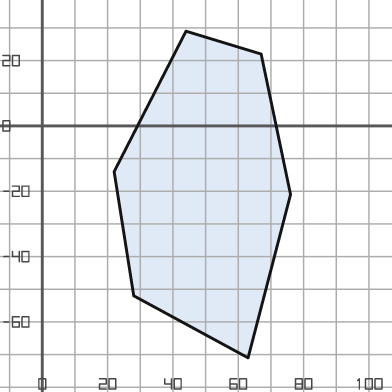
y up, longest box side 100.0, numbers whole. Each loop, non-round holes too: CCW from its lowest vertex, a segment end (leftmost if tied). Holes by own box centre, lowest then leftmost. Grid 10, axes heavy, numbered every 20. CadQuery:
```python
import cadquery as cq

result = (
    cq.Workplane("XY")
    .moveTo(63.0, -71.0)
    .lineTo(76.0, -21.0)
    .lineTo(67.0, 22.0)
    .lineTo(44.0, 29.0)
    .lineTo(22.0, -14.0)
    .lineTo(28.0, -52.0)
    .close()
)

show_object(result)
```